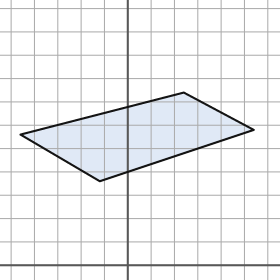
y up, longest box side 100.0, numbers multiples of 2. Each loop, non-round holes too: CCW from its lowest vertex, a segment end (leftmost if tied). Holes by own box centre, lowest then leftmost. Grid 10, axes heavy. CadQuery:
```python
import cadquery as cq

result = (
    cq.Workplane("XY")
    .moveTo(-12.0, 36.0)
    .lineTo(54.0, 58.0)
    .lineTo(24.0, 74.0)
    .lineTo(-46.0, 56.0)
    .close()
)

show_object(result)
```